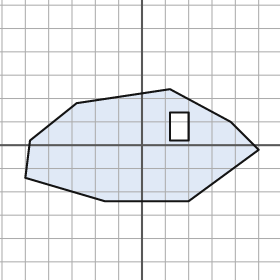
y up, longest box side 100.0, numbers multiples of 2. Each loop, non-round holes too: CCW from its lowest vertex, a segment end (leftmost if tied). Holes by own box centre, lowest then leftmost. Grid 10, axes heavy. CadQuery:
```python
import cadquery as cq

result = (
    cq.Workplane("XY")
    .moveTo(-16.0, -24.0)
    .lineTo(20.0, -24.0)
    .lineTo(50.0, -2.0)
    .lineTo(38.0, 10.0)
    .lineTo(12.0, 24.0)
    .lineTo(-28.0, 18.0)
    .lineTo(-48.0, 2.0)
    .lineTo(-50.0, -14.0)
    .close()
    .moveTo(12.0, 2.0)
    .lineTo(20.0, 2.0)
    .lineTo(20.0, 14.0)
    .lineTo(12.0, 14.0)
    .close()
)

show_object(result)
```